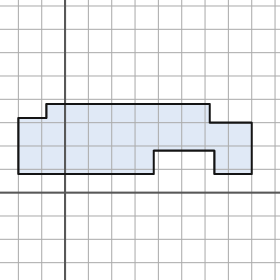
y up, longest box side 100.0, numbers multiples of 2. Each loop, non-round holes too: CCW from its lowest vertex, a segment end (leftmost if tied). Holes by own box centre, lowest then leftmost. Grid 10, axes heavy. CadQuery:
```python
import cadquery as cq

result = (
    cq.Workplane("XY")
    .moveTo(-20.0, 8.0)
    .lineTo(38.0, 8.0)
    .lineTo(38.0, 18.0)
    .lineTo(64.0, 18.0)
    .lineTo(64.0, 8.0)
    .lineTo(80.0, 8.0)
    .lineTo(80.0, 30.0)
    .lineTo(62.0, 30.0)
    .lineTo(62.0, 38.0)
    .lineTo(-8.0, 38.0)
    .lineTo(-8.0, 32.0)
    .lineTo(-20.0, 32.0)
    .close()
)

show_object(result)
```